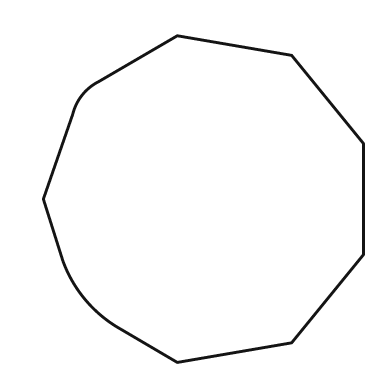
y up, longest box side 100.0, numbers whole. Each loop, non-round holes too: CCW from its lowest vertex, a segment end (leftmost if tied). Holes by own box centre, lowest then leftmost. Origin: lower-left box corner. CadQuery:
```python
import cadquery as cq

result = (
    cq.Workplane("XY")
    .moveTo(41.0, 0.0)
    .lineTo(76.0, 6.0)
    .lineTo(98.0, 33.0)
    .lineTo(98.0, 67.0)
    .lineTo(76.0, 94.0)
    .lineTo(41.0, 100.0)
    .lineTo(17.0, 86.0)
    .threePointArc((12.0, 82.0), (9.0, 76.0))
    .lineTo(0.0, 50.0)
    .lineTo(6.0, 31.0)
    .threePointArc((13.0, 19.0), (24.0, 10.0))
    .close()
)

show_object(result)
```